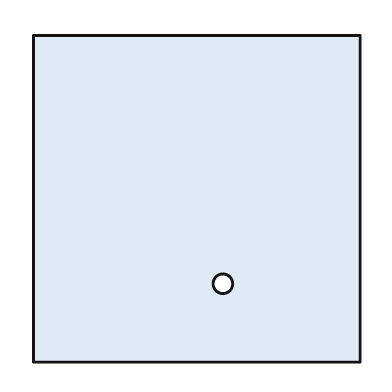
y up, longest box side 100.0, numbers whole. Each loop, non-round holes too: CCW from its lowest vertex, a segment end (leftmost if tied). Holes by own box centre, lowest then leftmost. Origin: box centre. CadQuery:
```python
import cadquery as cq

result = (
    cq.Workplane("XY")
    .moveTo(-50.0, -50.0)
    .lineTo(50.0, -50.0)
    .lineTo(50.0, 50.0)
    .lineTo(-50.0, 50.0)
    .close()
    .moveTo(8.0, -26.0)
    .circle(3.0)
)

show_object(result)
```